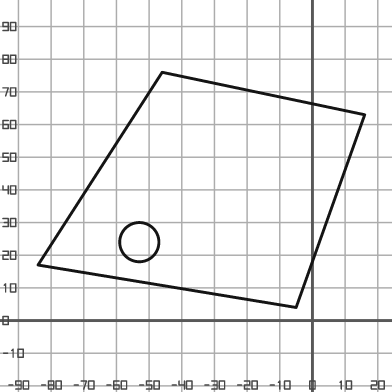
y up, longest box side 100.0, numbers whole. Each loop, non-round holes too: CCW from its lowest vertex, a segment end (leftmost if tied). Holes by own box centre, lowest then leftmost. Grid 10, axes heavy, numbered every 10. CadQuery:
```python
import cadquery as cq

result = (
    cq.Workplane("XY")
    .moveTo(-5.0, 4.0)
    .lineTo(16.0, 63.0)
    .lineTo(-46.0, 76.0)
    .lineTo(-84.0, 17.0)
    .close()
    .moveTo(-53.0, 24.0)
    .circle(6.0)
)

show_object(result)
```